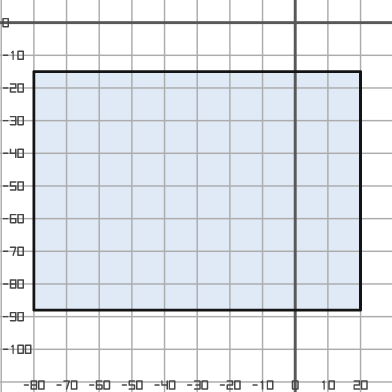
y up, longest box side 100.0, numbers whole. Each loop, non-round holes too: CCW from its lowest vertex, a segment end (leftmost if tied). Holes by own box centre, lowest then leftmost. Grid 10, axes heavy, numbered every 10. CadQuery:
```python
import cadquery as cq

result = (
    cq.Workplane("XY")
    .moveTo(-80.0, -88.0)
    .lineTo(20.0, -88.0)
    .lineTo(20.0, -15.0)
    .lineTo(-80.0, -15.0)
    .close()
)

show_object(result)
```